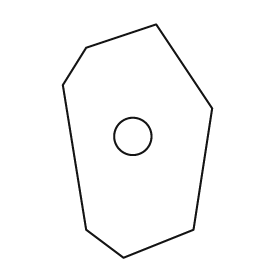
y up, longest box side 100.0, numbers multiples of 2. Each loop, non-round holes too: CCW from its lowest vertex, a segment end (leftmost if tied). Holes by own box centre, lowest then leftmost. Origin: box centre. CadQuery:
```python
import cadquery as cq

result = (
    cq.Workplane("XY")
    .moveTo(-6.0, -50.0)
    .lineTo(24.0, -38.0)
    .lineTo(32.0, 14.0)
    .lineTo(8.0, 50.0)
    .lineTo(-22.0, 40.0)
    .lineTo(-32.0, 24.0)
    .lineTo(-22.0, -38.0)
    .close()
    .moveTo(-2.0, 2.0)
    .circle(8.0)
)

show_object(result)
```